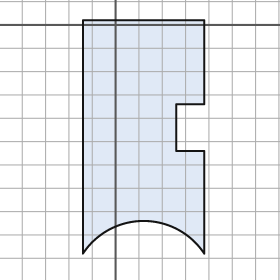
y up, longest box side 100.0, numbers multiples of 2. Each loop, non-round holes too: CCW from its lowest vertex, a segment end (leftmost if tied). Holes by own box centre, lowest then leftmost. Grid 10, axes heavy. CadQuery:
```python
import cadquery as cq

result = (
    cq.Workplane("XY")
    .moveTo(-14.0, -98.0)
    .threePointArc((12.0, -84.0), (38.0, -98.0))
    .lineTo(38.0, -54.0)
    .lineTo(26.0, -54.0)
    .lineTo(26.0, -34.0)
    .lineTo(38.0, -34.0)
    .lineTo(38.0, 2.0)
    .lineTo(-14.0, 2.0)
    .close()
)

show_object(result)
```